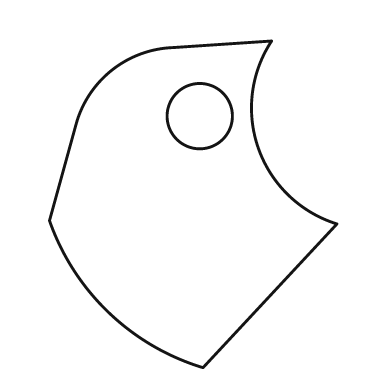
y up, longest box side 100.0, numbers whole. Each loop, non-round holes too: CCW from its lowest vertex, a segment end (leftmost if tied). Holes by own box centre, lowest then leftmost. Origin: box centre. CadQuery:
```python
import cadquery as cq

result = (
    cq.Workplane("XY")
    .moveTo(3.0, -50.0)
    .lineTo(44.0, -6.0)
    .threePointArc((20.0, 17.0), (24.0, 50.0))
    .lineTo(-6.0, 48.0)
    .threePointArc((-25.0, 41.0), (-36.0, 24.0))
    .lineTo(-44.0, -5.0)
    .threePointArc((-26.0, -33.0), (3.0, -50.0))
    .close()
    .moveTo(2.0, 27.0)
    .circle(10.0)
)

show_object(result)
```